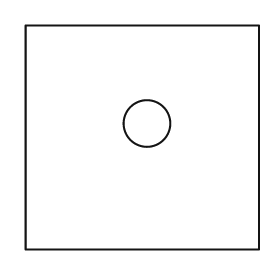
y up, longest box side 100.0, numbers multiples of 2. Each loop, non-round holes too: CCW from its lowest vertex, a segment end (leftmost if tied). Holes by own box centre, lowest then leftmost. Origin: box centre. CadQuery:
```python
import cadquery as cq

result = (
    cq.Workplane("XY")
    .moveTo(-50.0, -48.0)
    .lineTo(50.0, -48.0)
    .lineTo(50.0, 48.0)
    .lineTo(-50.0, 48.0)
    .close()
    .moveTo(2.0, 6.0)
    .circle(10.0)
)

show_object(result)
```